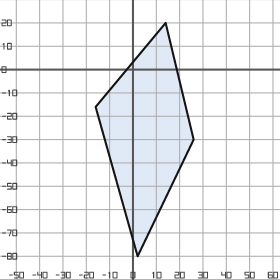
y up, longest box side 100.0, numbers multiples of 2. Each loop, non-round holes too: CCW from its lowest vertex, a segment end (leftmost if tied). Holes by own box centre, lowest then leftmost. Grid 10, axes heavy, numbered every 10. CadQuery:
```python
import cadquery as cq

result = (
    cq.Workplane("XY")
    .moveTo(2.0, -80.0)
    .lineTo(26.0, -30.0)
    .lineTo(14.0, 20.0)
    .lineTo(-16.0, -16.0)
    .close()
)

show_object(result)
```